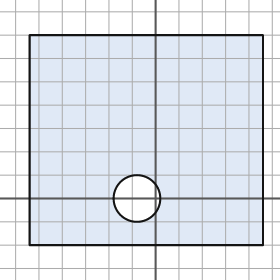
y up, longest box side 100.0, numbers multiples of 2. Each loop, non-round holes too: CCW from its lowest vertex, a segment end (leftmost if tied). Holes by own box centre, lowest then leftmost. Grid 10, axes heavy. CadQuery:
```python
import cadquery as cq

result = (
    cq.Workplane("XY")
    .moveTo(-54.0, -20.0)
    .lineTo(46.0, -20.0)
    .lineTo(46.0, 70.0)
    .lineTo(-54.0, 70.0)
    .close()
    .moveTo(-8.0, 0.0)
    .circle(10.0)
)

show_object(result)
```